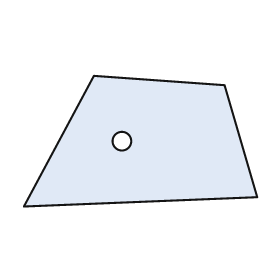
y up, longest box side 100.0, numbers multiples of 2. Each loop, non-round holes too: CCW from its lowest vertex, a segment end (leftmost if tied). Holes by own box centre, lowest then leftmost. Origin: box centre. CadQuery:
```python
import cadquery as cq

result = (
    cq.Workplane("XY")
    .moveTo(-50.0, -28.0)
    .lineTo(50.0, -24.0)
    .lineTo(36.0, 24.0)
    .lineTo(-20.0, 28.0)
    .close()
    .moveTo(-8.0, 0.0)
    .circle(4.0)
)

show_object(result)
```